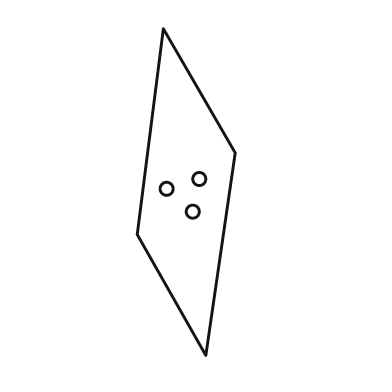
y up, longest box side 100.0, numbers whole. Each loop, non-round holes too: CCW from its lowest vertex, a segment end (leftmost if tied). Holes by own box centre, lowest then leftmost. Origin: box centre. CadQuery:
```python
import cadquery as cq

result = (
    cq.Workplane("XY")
    .moveTo(6.0, -50.0)
    .lineTo(15.0, 12.0)
    .lineTo(-7.0, 50.0)
    .lineTo(-15.0, -13.0)
    .close()
    .moveTo(2.0, -6.0)
    .circle(2.0)
    .moveTo(-6.0, 1.0)
    .circle(2.0)
    .moveTo(4.0, 4.0)
    .circle(2.0)
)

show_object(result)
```